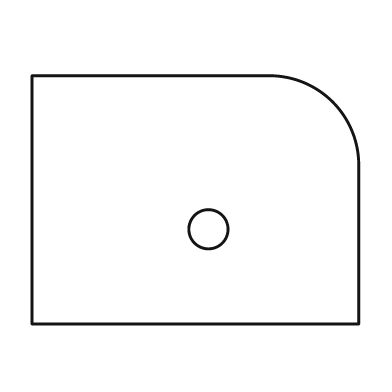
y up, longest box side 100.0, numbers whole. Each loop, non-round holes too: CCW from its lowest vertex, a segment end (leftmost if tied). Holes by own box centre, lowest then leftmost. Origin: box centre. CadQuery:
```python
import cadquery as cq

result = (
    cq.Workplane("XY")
    .moveTo(-50.0, -38.0)
    .lineTo(50.0, -38.0)
    .lineTo(50.0, 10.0)
    .threePointArc((42.0, 30.0), (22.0, 38.0))
    .lineTo(-50.0, 38.0)
    .close()
    .moveTo(4.0, -9.0)
    .circle(6.0)
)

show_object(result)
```